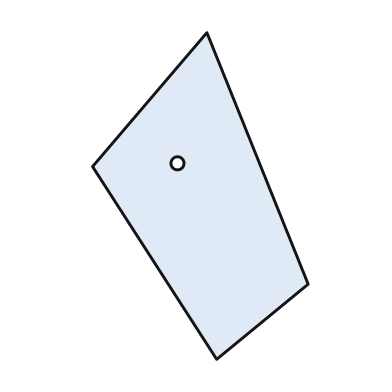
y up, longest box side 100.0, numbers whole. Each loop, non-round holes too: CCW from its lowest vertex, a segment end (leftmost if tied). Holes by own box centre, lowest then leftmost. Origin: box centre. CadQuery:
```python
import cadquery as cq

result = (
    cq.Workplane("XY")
    .moveTo(5.0, -50.0)
    .lineTo(33.0, -27.0)
    .lineTo(2.0, 50.0)
    .lineTo(-33.0, 9.0)
    .close()
    .moveTo(-7.0, 10.0)
    .circle(2.0)
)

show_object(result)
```